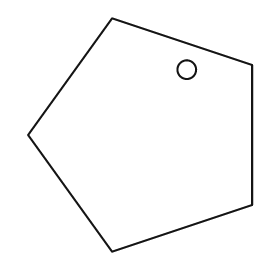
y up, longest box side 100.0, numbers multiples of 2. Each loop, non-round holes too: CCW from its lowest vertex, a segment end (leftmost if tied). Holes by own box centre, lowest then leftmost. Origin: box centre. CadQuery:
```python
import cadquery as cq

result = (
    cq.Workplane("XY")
    .moveTo(-12.0, -50.0)
    .lineTo(48.0, -30.0)
    .lineTo(48.0, 30.0)
    .lineTo(-12.0, 50.0)
    .lineTo(-48.0, 0.0)
    .close()
    .moveTo(20.0, 28.0)
    .circle(4.0)
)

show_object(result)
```